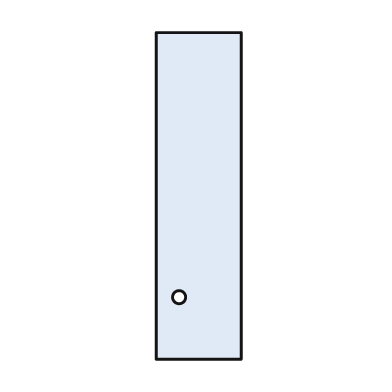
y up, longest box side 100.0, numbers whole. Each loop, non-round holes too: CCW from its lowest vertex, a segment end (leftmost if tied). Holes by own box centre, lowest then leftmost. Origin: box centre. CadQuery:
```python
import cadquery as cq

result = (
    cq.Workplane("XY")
    .moveTo(-13.0, -50.0)
    .lineTo(13.0, -50.0)
    .lineTo(13.0, 50.0)
    .lineTo(-13.0, 50.0)
    .close()
    .moveTo(-6.0, -31.0)
    .circle(2.0)
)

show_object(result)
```